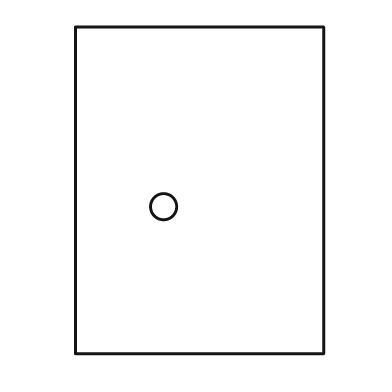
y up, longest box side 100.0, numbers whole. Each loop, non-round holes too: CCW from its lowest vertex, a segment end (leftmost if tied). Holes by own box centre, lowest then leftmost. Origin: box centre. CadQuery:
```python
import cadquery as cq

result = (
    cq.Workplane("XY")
    .moveTo(-38.0, -50.0)
    .lineTo(38.0, -50.0)
    .lineTo(38.0, 50.0)
    .lineTo(-38.0, 50.0)
    .close()
    .moveTo(-11.0, -5.0)
    .circle(4.0)
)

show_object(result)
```